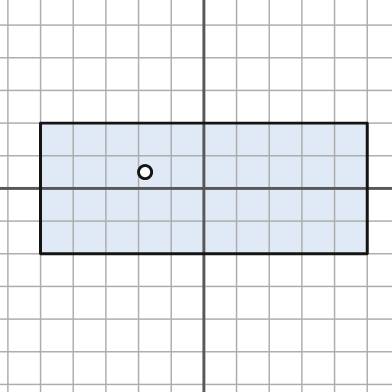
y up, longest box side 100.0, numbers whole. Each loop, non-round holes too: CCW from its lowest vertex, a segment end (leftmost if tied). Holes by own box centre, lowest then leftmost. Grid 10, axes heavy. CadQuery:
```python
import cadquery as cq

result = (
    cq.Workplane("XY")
    .moveTo(-50.0, -20.0)
    .lineTo(50.0, -20.0)
    .lineTo(50.0, 20.0)
    .lineTo(-50.0, 20.0)
    .close()
    .moveTo(-18.0, 5.0)
    .circle(2.0)
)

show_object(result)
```